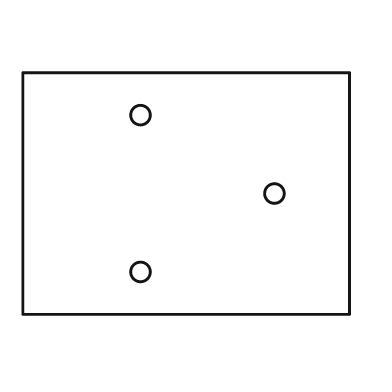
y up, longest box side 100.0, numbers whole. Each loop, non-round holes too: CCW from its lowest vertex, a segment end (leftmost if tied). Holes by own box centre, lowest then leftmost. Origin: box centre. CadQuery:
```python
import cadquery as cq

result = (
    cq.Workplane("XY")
    .moveTo(-50.0, -37.0)
    .lineTo(50.0, -37.0)
    .lineTo(50.0, 37.0)
    .lineTo(-50.0, 37.0)
    .close()
    .moveTo(-14.0, -24.0)
    .circle(3.0)
    .moveTo(27.0, 0.0)
    .circle(3.0)
    .moveTo(-14.0, 24.0)
    .circle(3.0)
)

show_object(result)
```